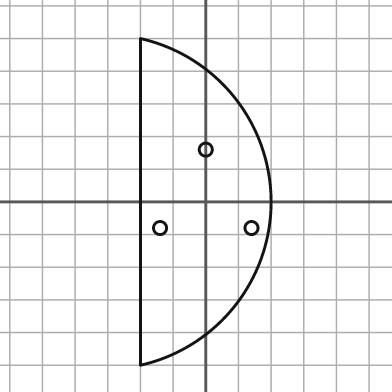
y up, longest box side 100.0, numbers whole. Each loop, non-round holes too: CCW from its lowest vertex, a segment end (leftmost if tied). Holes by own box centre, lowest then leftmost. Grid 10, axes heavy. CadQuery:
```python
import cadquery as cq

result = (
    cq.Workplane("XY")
    .moveTo(-20.0, -50.0)
    .threePointArc((20.0, 0.0), (-20.0, 50.0))
    .close()
    .moveTo(-14.0, -8.0)
    .circle(2.0)
    .moveTo(14.0, -8.0)
    .circle(2.0)
    .moveTo(0.0, 16.0)
    .circle(2.0)
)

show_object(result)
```